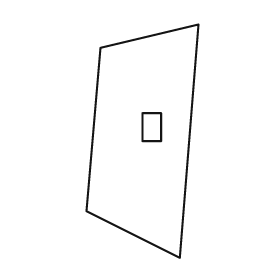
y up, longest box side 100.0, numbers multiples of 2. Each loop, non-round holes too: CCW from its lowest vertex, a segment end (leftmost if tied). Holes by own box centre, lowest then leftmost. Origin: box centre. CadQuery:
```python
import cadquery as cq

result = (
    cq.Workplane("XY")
    .moveTo(16.0, -50.0)
    .lineTo(24.0, 50.0)
    .lineTo(-18.0, 40.0)
    .lineTo(-24.0, -30.0)
    .close()
    .moveTo(0.0, 0.0)
    .lineTo(8.0, 0.0)
    .lineTo(8.0, 12.0)
    .lineTo(0.0, 12.0)
    .close()
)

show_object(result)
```